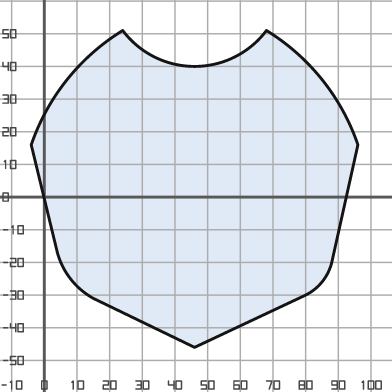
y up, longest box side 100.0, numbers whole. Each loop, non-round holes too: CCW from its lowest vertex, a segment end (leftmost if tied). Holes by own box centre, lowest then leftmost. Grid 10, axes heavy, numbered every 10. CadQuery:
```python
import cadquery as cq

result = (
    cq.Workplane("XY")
    .moveTo(46.0, -46.0)
    .lineTo(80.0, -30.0)
    .threePointArc((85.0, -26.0), (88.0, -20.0))
    .lineTo(96.0, 16.0)
    .threePointArc((85.0, 36.0), (68.0, 51.0))
    .threePointArc((46.0, 40.0), (24.0, 51.0))
    .threePointArc((7.0, 36.0), (-4.0, 16.0))
    .lineTo(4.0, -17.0)
    .threePointArc((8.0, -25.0), (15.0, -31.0))
    .close()
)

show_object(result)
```